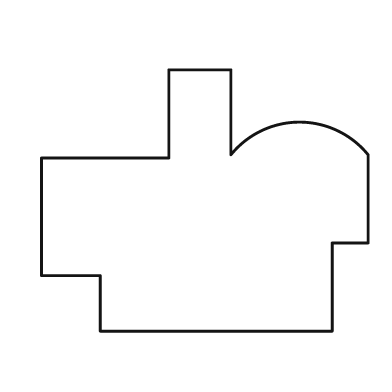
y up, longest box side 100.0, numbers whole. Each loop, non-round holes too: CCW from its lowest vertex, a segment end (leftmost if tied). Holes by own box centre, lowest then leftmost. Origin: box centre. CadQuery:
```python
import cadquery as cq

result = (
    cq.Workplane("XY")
    .moveTo(-32.0, -40.0)
    .lineTo(39.0, -40.0)
    .lineTo(39.0, -13.0)
    .lineTo(50.0, -13.0)
    .lineTo(50.0, 14.0)
    .threePointArc((29.0, 24.0), (8.0, 14.0))
    .lineTo(8.0, 40.0)
    .lineTo(-11.0, 40.0)
    .lineTo(-11.0, 13.0)
    .lineTo(-50.0, 13.0)
    .lineTo(-50.0, -23.0)
    .lineTo(-32.0, -23.0)
    .close()
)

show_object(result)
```